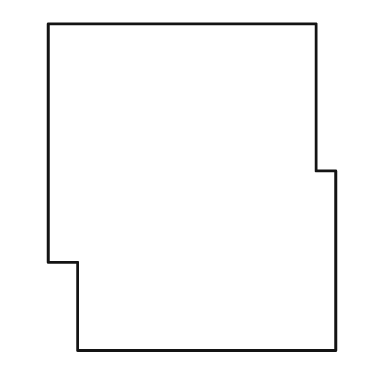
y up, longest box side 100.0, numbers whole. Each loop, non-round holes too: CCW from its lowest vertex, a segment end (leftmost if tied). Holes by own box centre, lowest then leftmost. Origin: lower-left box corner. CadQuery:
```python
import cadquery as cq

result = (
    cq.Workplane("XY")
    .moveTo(9.0, 0.0)
    .lineTo(88.0, 0.0)
    .lineTo(88.0, 55.0)
    .lineTo(82.0, 55.0)
    .lineTo(82.0, 100.0)
    .lineTo(0.0, 100.0)
    .lineTo(0.0, 27.0)
    .lineTo(9.0, 27.0)
    .close()
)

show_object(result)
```